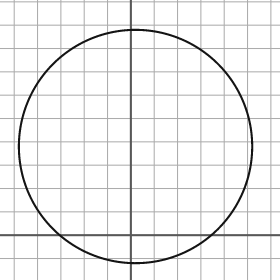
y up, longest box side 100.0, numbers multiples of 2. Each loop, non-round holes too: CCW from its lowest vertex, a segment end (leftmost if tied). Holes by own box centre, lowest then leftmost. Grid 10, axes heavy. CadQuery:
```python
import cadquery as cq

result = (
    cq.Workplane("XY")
    .moveTo(2.0, 38.0)
    .circle(50.0)
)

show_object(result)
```